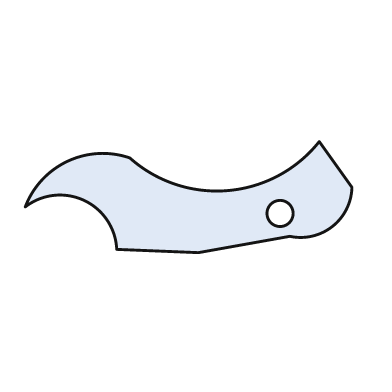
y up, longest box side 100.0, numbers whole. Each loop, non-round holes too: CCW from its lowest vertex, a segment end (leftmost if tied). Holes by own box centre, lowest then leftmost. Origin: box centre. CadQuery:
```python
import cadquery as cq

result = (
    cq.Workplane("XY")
    .moveTo(3.0, -17.0)
    .lineTo(31.0, -12.0)
    .threePointArc((44.0, -9.0), (50.0, 3.0))
    .lineTo(40.0, 17.0)
    .threePointArc((12.0, 2.0), (-18.0, 12.0))
    .threePointArc((-37.0, 11.0), (-50.0, -3.0))
    .threePointArc((-32.0, -1.0), (-22.0, -16.0))
    .close()
    .moveTo(28.0, -5.0)
    .circle(4.0)
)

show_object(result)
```